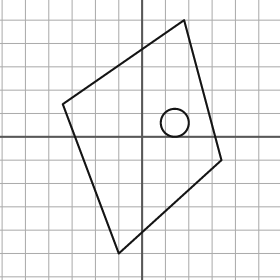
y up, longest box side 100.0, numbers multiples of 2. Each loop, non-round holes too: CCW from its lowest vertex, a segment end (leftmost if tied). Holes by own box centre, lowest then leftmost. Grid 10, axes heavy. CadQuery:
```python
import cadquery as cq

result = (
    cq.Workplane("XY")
    .moveTo(-10.0, -50.0)
    .lineTo(34.0, -10.0)
    .lineTo(18.0, 50.0)
    .lineTo(-34.0, 14.0)
    .close()
    .moveTo(14.0, 6.0)
    .circle(6.0)
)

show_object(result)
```